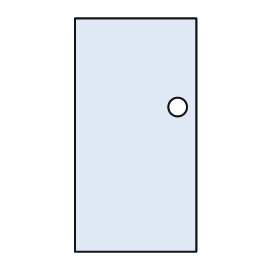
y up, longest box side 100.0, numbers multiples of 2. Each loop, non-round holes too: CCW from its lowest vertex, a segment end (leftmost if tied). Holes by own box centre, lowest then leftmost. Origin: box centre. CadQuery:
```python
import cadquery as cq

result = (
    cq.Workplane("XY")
    .moveTo(-26.0, -50.0)
    .lineTo(26.0, -50.0)
    .lineTo(26.0, 50.0)
    .lineTo(-26.0, 50.0)
    .close()
    .moveTo(18.0, 12.0)
    .circle(4.0)
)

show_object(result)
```